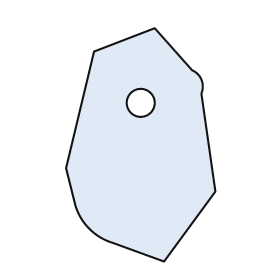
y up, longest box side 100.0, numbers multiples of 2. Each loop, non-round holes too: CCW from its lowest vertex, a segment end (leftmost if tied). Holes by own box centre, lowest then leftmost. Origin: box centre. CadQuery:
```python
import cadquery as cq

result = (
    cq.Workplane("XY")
    .moveTo(10.0, -50.0)
    .lineTo(32.0, -20.0)
    .lineTo(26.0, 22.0)
    .threePointArc((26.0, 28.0), (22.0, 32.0))
    .lineTo(6.0, 50.0)
    .lineTo(-20.0, 40.0)
    .lineTo(-32.0, -10.0)
    .lineTo(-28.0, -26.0)
    .threePointArc((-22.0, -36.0), (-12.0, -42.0))
    .close()
    .moveTo(0.0, 18.0)
    .circle(6.0)
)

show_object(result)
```